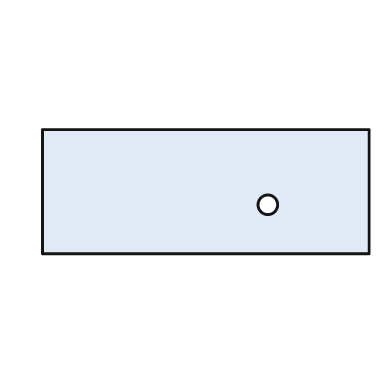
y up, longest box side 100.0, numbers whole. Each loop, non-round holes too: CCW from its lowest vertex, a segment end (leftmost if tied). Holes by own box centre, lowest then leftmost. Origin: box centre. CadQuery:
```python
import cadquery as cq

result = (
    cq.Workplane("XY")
    .moveTo(-50.0, -19.0)
    .lineTo(50.0, -19.0)
    .lineTo(50.0, 19.0)
    .lineTo(-50.0, 19.0)
    .close()
    .moveTo(19.0, -4.0)
    .circle(3.0)
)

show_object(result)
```